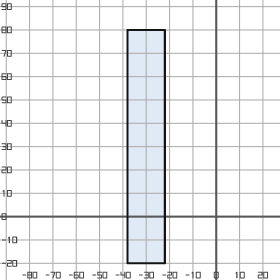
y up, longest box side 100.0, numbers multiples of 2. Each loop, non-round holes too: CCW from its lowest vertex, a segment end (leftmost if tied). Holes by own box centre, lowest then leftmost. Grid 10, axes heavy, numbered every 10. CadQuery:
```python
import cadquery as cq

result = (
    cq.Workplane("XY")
    .moveTo(-38.0, -20.0)
    .lineTo(-22.0, -20.0)
    .lineTo(-22.0, 80.0)
    .lineTo(-38.0, 80.0)
    .close()
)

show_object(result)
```